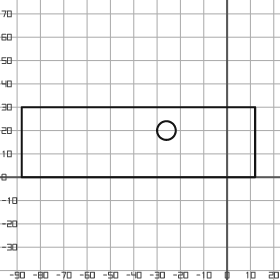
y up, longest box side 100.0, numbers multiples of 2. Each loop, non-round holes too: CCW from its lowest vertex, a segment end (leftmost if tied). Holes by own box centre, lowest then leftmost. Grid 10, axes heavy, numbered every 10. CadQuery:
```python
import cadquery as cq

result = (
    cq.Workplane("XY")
    .moveTo(-88.0, 0.0)
    .lineTo(12.0, 0.0)
    .lineTo(12.0, 30.0)
    .lineTo(-88.0, 30.0)
    .close()
    .moveTo(-26.0, 20.0)
    .circle(4.0)
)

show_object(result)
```